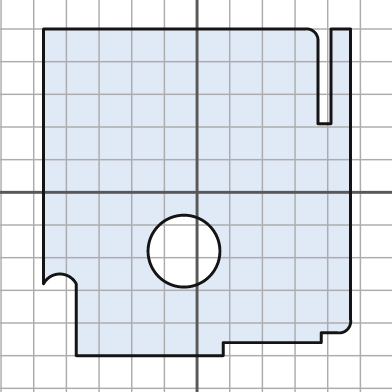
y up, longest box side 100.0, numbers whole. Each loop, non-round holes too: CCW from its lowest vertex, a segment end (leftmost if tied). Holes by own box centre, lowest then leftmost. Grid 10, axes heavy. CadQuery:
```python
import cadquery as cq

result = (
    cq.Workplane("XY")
    .moveTo(-37.0, -50.0)
    .lineTo(8.0, -50.0)
    .lineTo(8.0, -46.0)
    .lineTo(38.0, -46.0)
    .lineTo(38.0, -43.0)
    .lineTo(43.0, -43.0)
    .threePointArc((46.0, -42.0), (47.0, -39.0))
    .lineTo(47.0, 50.0)
    .lineTo(41.0, 50.0)
    .lineTo(41.0, 21.0)
    .lineTo(37.0, 21.0)
    .lineTo(37.0, 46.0)
    .threePointArc((36.0, 49.0), (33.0, 50.0))
    .lineTo(-47.0, 50.0)
    .lineTo(-47.0, -28.0)
    .threePointArc((-42.0, -25.0), (-37.0, -28.0))
    .close()
    .moveTo(-4.0, -18.0)
    .circle(11.0)
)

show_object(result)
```